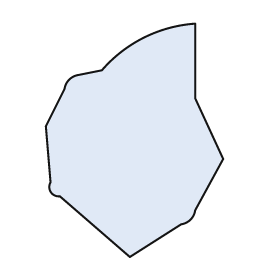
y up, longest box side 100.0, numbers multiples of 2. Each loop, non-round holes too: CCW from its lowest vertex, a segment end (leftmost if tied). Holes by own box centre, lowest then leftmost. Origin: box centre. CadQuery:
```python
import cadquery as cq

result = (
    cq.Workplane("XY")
    .moveTo(-2.0, -50.0)
    .lineTo(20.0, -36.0)
    .threePointArc((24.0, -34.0), (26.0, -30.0))
    .lineTo(38.0, -8.0)
    .lineTo(26.0, 18.0)
    .lineTo(26.0, 50.0)
    .threePointArc((4.0, 44.0), (-14.0, 30.0))
    .lineTo(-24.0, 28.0)
    .threePointArc((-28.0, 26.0), (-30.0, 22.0))
    .lineTo(-38.0, 6.0)
    .lineTo(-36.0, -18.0)
    .threePointArc((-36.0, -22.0), (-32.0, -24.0))
    .close()
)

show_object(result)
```